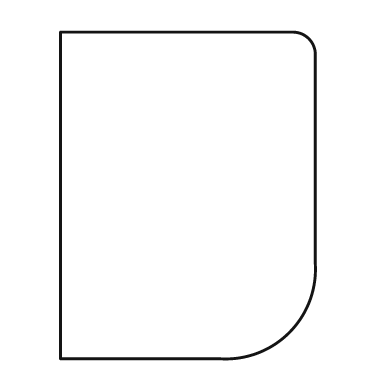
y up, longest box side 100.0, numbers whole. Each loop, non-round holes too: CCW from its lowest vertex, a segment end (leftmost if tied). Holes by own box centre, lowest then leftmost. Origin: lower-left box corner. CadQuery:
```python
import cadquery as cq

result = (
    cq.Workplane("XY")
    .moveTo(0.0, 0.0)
    .lineTo(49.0, 0.0)
    .threePointArc((70.0, 8.0), (78.0, 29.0))
    .lineTo(78.0, 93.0)
    .threePointArc((76.0, 98.0), (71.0, 100.0))
    .lineTo(0.0, 100.0)
    .close()
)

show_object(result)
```